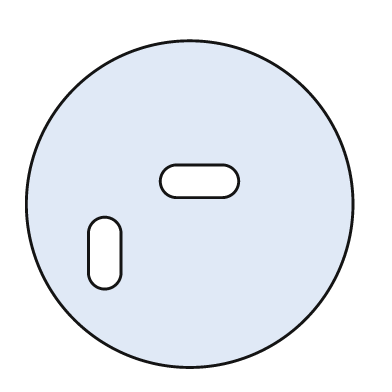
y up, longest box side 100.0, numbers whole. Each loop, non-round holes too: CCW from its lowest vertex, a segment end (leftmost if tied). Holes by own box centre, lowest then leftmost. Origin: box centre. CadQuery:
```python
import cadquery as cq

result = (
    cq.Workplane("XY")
    .moveTo(0.0, 0.0)
    .circle(50.0)
    .moveTo(-31.0, -21.0)
    .threePointArc((-26.0, -26.0), (-21.0, -21.0))
    .lineTo(-21.0, -9.0)
    .threePointArc((-26.0, -4.0), (-31.0, -9.0))
    .close()
    .moveTo(-4.0, 2.0)
    .lineTo(10.0, 2.0)
    .threePointArc((15.0, 7.0), (10.0, 12.0))
    .lineTo(-4.0, 12.0)
    .threePointArc((-9.0, 7.0), (-4.0, 2.0))
    .close()
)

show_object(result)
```